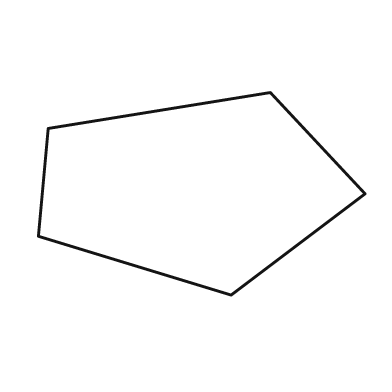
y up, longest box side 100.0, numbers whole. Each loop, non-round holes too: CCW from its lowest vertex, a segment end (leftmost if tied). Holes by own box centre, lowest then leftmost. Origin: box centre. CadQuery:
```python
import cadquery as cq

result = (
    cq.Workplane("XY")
    .moveTo(9.0, -31.0)
    .lineTo(50.0, 0.0)
    .lineTo(21.0, 31.0)
    .lineTo(-47.0, 20.0)
    .lineTo(-50.0, -13.0)
    .close()
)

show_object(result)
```